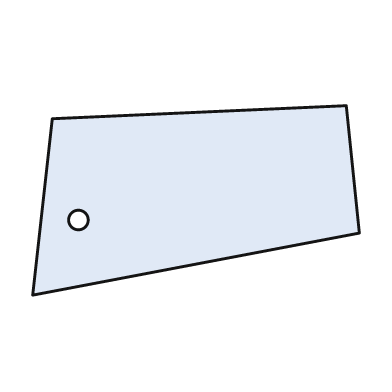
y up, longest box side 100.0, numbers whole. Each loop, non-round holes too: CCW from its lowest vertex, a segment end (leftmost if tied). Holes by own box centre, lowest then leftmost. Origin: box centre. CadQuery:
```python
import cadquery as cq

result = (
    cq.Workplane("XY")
    .moveTo(-50.0, -29.0)
    .lineTo(50.0, -10.0)
    .lineTo(46.0, 29.0)
    .lineTo(-44.0, 25.0)
    .close()
    .moveTo(-36.0, -6.0)
    .circle(3.0)
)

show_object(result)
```